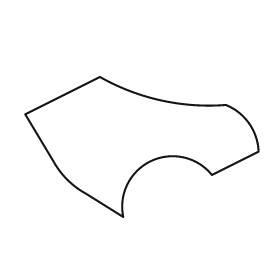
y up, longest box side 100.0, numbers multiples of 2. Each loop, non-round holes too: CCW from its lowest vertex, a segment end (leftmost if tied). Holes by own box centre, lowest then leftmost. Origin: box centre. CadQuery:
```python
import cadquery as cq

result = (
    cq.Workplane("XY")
    .moveTo(-8.0, -30.0)
    .threePointArc((4.0, -6.0), (30.0, -12.0))
    .lineTo(50.0, -2.0)
    .threePointArc((46.0, 10.0), (36.0, 18.0))
    .threePointArc((8.0, 20.0), (-18.0, 30.0))
    .lineTo(-50.0, 14.0)
    .lineTo(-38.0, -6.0)
    .threePointArc((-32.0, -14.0), (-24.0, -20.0))
    .close()
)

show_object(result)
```